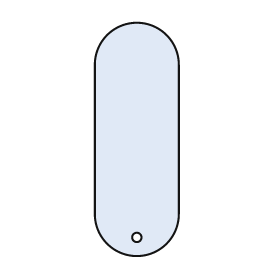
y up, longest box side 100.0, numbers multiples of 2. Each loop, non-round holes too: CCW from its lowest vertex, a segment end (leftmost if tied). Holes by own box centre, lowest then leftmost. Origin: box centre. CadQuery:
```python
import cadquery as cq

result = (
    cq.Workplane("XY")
    .moveTo(-18.0, -32.0)
    .threePointArc((0.0, -50.0), (18.0, -32.0))
    .lineTo(18.0, 32.0)
    .threePointArc((0.0, 50.0), (-18.0, 32.0))
    .close()
    .moveTo(0.0, -42.0)
    .circle(2.0)
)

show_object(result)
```